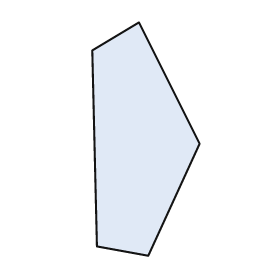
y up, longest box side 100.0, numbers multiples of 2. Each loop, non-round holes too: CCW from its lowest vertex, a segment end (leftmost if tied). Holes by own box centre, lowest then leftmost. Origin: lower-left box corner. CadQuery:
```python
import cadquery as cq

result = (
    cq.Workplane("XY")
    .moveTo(24.0, 0.0)
    .lineTo(46.0, 48.0)
    .lineTo(20.0, 100.0)
    .lineTo(0.0, 88.0)
    .lineTo(2.0, 4.0)
    .close()
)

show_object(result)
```